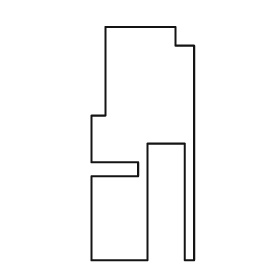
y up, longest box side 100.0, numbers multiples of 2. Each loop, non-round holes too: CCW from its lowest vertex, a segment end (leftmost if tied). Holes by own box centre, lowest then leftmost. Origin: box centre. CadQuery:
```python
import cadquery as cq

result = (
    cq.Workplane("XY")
    .moveTo(-22.0, -50.0)
    .lineTo(2.0, -50.0)
    .lineTo(2.0, 0.0)
    .lineTo(18.0, 0.0)
    .lineTo(18.0, -50.0)
    .lineTo(22.0, -50.0)
    .lineTo(22.0, 42.0)
    .lineTo(14.0, 42.0)
    .lineTo(14.0, 50.0)
    .lineTo(-16.0, 50.0)
    .lineTo(-16.0, 12.0)
    .lineTo(-22.0, 12.0)
    .lineTo(-22.0, -8.0)
    .lineTo(-2.0, -8.0)
    .lineTo(-2.0, -14.0)
    .lineTo(-22.0, -14.0)
    .close()
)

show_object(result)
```